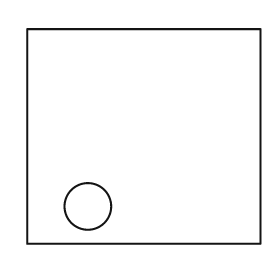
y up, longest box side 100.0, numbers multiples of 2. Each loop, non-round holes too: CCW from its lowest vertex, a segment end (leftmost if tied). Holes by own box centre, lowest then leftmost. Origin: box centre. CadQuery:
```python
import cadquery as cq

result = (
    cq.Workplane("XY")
    .moveTo(-50.0, -46.0)
    .lineTo(50.0, -46.0)
    .lineTo(50.0, 46.0)
    .lineTo(-50.0, 46.0)
    .close()
    .moveTo(-24.0, -30.0)
    .circle(10.0)
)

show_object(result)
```